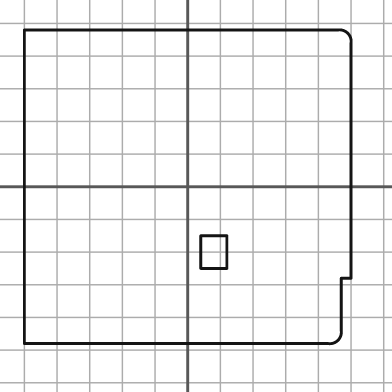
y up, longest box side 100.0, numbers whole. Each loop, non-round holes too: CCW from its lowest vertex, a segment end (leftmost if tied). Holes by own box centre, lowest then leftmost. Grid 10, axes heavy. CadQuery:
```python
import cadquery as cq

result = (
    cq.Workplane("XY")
    .moveTo(-50.0, -48.0)
    .lineTo(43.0, -48.0)
    .threePointArc((46.0, -47.0), (47.0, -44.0))
    .lineTo(47.0, -28.0)
    .lineTo(50.0, -28.0)
    .lineTo(50.0, 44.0)
    .threePointArc((49.0, 47.0), (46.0, 48.0))
    .lineTo(-50.0, 48.0)
    .close()
    .moveTo(4.0, -25.0)
    .lineTo(12.0, -25.0)
    .lineTo(12.0, -15.0)
    .lineTo(4.0, -15.0)
    .close()
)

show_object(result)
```